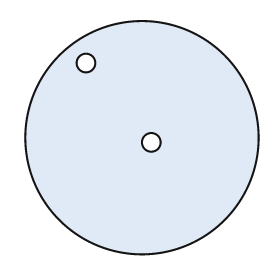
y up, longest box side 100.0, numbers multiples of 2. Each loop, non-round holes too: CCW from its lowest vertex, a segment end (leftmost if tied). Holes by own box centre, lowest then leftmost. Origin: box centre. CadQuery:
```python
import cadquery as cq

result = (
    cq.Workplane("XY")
    .moveTo(0.0, 0.0)
    .circle(50.0)
    .moveTo(4.0, -2.0)
    .circle(4.0)
    .moveTo(-24.0, 32.0)
    .circle(4.0)
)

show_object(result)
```